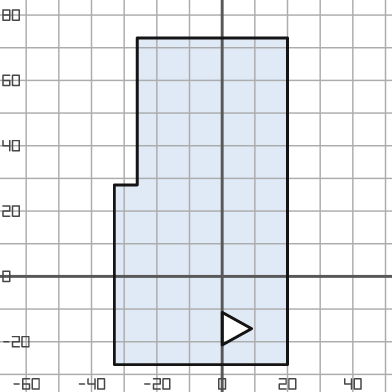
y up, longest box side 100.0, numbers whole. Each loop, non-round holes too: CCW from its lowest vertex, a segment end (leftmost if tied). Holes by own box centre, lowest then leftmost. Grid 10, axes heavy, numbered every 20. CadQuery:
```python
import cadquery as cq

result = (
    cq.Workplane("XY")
    .moveTo(-33.0, -27.0)
    .lineTo(20.0, -27.0)
    .lineTo(20.0, 73.0)
    .lineTo(-26.0, 73.0)
    .lineTo(-26.0, 28.0)
    .lineTo(-33.0, 28.0)
    .close()
    .moveTo(0.0, -21.0)
    .lineTo(9.0, -16.0)
    .lineTo(0.0, -11.0)
    .close()
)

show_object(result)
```